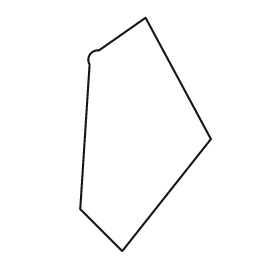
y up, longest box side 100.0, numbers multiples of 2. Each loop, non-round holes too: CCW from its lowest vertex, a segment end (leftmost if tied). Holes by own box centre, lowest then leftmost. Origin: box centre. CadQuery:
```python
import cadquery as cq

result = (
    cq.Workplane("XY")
    .moveTo(-10.0, -50.0)
    .lineTo(28.0, -2.0)
    .lineTo(0.0, 50.0)
    .lineTo(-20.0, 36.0)
    .threePointArc((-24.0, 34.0), (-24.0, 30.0))
    .lineTo(-28.0, -32.0)
    .close()
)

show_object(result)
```